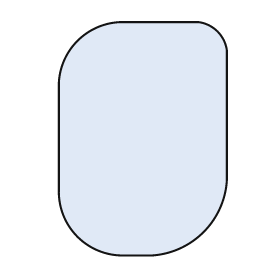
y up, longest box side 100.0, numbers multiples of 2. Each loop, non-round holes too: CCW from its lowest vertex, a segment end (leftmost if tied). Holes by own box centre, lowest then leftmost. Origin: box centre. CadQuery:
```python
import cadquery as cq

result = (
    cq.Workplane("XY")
    .moveTo(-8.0, -50.0)
    .lineTo(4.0, -50.0)
    .threePointArc((26.0, -40.0), (36.0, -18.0))
    .lineTo(36.0, 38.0)
    .threePointArc((32.0, 46.0), (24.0, 50.0))
    .lineTo(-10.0, 50.0)
    .threePointArc((-28.0, 42.0), (-36.0, 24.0))
    .lineTo(-36.0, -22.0)
    .threePointArc((-28.0, -42.0), (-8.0, -50.0))
    .close()
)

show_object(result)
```